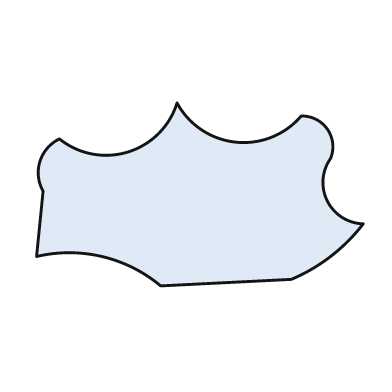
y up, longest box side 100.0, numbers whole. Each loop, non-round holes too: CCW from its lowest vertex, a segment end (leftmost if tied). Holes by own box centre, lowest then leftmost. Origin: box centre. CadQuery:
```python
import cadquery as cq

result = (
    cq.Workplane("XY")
    .moveTo(-12.0, -28.0)
    .lineTo(28.0, -26.0)
    .threePointArc((40.0, -19.0), (50.0, -9.0))
    .threePointArc((39.0, -2.0), (40.0, 11.0))
    .threePointArc((39.0, 20.0), (31.0, 24.0))
    .threePointArc((11.0, 16.0), (-7.0, 28.0))
    .threePointArc((-22.0, 13.0), (-43.0, 17.0))
    .threePointArc((-49.0, 10.0), (-48.0, 1.0))
    .lineTo(-50.0, -19.0)
    .threePointArc((-30.0, -19.0), (-12.0, -28.0))
    .close()
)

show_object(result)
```